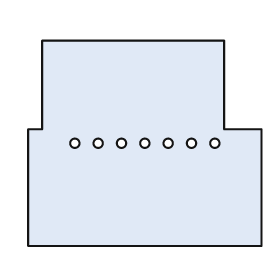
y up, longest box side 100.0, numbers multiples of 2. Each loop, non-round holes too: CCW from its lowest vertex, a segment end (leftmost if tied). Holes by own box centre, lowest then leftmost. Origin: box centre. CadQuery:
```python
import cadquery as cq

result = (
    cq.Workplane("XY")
    .moveTo(-50.0, -44.0)
    .lineTo(50.0, -44.0)
    .lineTo(50.0, 6.0)
    .lineTo(34.0, 6.0)
    .lineTo(34.0, 44.0)
    .lineTo(-44.0, 44.0)
    .lineTo(-44.0, 6.0)
    .lineTo(-50.0, 6.0)
    .close()
    .moveTo(-30.0, 0.0)
    .circle(2.0)
    .moveTo(-20.0, 0.0)
    .circle(2.0)
    .moveTo(-10.0, 0.0)
    .circle(2.0)
    .moveTo(0.0, 0.0)
    .circle(2.0)
    .moveTo(10.0, 0.0)
    .circle(2.0)
    .moveTo(20.0, 0.0)
    .circle(2.0)
    .moveTo(30.0, 0.0)
    .circle(2.0)
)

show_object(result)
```